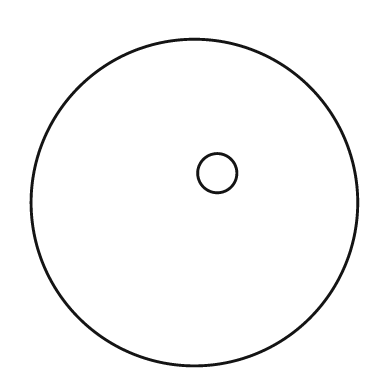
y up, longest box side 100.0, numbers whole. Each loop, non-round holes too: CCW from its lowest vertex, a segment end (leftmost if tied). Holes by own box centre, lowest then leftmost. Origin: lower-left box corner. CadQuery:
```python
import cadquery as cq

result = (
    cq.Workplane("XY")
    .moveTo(50.0, 50.0)
    .circle(50.0)
    .moveTo(57.0, 59.0)
    .circle(6.0)
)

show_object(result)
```